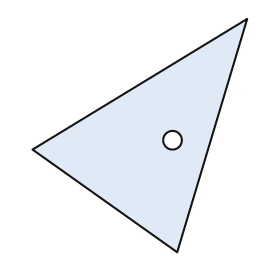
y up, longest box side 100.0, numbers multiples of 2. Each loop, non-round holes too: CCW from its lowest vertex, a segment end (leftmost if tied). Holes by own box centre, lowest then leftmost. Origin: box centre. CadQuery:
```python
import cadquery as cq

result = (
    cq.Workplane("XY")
    .moveTo(16.0, -50.0)
    .lineTo(46.0, 50.0)
    .lineTo(-46.0, -6.0)
    .close()
    .moveTo(14.0, -2.0)
    .circle(4.0)
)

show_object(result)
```